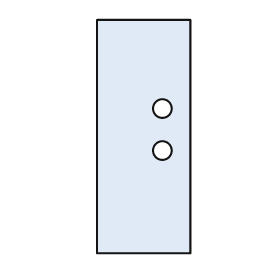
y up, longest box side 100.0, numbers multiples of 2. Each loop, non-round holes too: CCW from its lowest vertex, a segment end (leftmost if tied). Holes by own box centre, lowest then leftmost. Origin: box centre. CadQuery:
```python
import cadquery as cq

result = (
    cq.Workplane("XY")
    .moveTo(-20.0, -50.0)
    .lineTo(20.0, -50.0)
    .lineTo(20.0, 50.0)
    .lineTo(-20.0, 50.0)
    .close()
    .moveTo(8.0, -6.0)
    .circle(4.0)
    .moveTo(8.0, 12.0)
    .circle(4.0)
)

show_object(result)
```